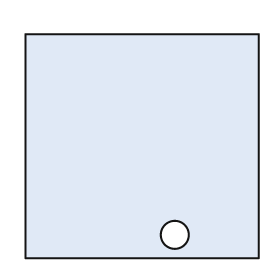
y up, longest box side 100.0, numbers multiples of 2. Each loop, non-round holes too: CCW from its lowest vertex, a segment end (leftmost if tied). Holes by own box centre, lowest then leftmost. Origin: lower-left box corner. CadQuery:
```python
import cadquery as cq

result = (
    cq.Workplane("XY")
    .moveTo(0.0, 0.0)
    .lineTo(100.0, 0.0)
    .lineTo(100.0, 96.0)
    .lineTo(0.0, 96.0)
    .close()
    .moveTo(64.0, 10.0)
    .circle(6.0)
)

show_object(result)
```